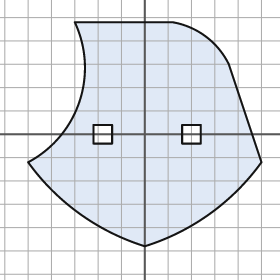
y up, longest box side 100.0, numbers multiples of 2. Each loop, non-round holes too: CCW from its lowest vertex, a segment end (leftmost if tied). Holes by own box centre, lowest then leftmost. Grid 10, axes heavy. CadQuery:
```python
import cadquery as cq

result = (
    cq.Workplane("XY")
    .moveTo(0.0, -48.0)
    .threePointArc((28.0, -34.0), (50.0, -12.0))
    .lineTo(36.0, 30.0)
    .threePointArc((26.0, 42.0), (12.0, 48.0))
    .lineTo(-30.0, 48.0)
    .threePointArc((-28.0, 14.0), (-50.0, -12.0))
    .threePointArc((-28.0, -34.0), (0.0, -48.0))
    .close()
    .moveTo(-22.0, -4.0)
    .lineTo(-14.0, -4.0)
    .lineTo(-14.0, 4.0)
    .lineTo(-22.0, 4.0)
    .close()
    .moveTo(16.0, -4.0)
    .lineTo(24.0, -4.0)
    .lineTo(24.0, 4.0)
    .lineTo(16.0, 4.0)
    .close()
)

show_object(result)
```